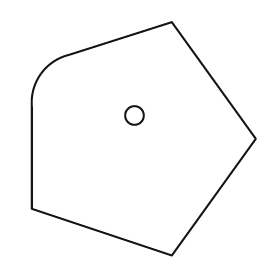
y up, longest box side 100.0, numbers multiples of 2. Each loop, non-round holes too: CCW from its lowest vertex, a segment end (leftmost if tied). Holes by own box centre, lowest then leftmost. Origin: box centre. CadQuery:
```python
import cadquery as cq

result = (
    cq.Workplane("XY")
    .moveTo(12.0, -50.0)
    .lineTo(48.0, 0.0)
    .lineTo(12.0, 50.0)
    .lineTo(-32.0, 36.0)
    .threePointArc((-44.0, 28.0), (-48.0, 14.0))
    .lineTo(-48.0, -30.0)
    .close()
    .moveTo(-4.0, 10.0)
    .circle(4.0)
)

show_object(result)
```